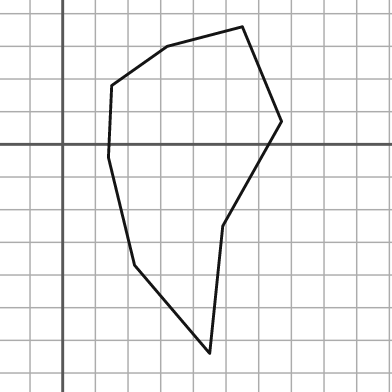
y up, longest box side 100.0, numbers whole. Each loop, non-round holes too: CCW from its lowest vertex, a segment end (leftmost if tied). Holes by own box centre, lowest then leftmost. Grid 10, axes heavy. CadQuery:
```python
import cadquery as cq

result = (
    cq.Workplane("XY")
    .moveTo(45.0, -64.0)
    .lineTo(49.0, -25.0)
    .lineTo(67.0, 7.0)
    .lineTo(55.0, 36.0)
    .lineTo(32.0, 30.0)
    .lineTo(15.0, 18.0)
    .lineTo(14.0, -4.0)
    .lineTo(22.0, -37.0)
    .close()
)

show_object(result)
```